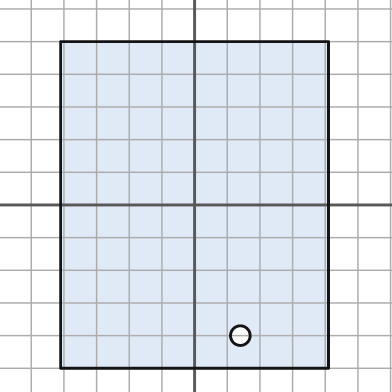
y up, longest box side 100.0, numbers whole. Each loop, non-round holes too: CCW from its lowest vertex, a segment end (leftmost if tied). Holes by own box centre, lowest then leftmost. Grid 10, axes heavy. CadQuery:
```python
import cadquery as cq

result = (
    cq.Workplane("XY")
    .moveTo(-41.0, -50.0)
    .lineTo(41.0, -50.0)
    .lineTo(41.0, 50.0)
    .lineTo(-41.0, 50.0)
    .close()
    .moveTo(14.0, -40.0)
    .circle(3.0)
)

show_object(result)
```